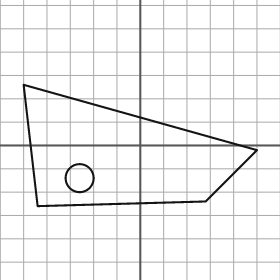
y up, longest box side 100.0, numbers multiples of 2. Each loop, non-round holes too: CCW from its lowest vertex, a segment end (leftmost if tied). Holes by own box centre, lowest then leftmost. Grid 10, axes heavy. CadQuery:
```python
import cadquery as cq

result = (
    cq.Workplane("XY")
    .moveTo(-44.0, -26.0)
    .lineTo(28.0, -24.0)
    .lineTo(50.0, -2.0)
    .lineTo(-50.0, 26.0)
    .close()
    .moveTo(-26.0, -14.0)
    .circle(6.0)
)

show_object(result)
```